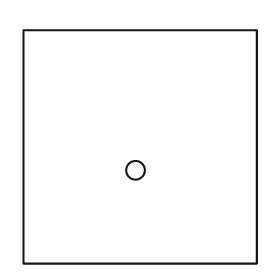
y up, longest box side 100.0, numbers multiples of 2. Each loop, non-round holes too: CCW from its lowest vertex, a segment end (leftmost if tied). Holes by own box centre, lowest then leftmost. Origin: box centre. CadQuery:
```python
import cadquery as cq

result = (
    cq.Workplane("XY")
    .moveTo(-50.0, -50.0)
    .lineTo(50.0, -50.0)
    .lineTo(50.0, 50.0)
    .lineTo(-50.0, 50.0)
    .close()
    .moveTo(-2.0, -10.0)
    .circle(4.0)
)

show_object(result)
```